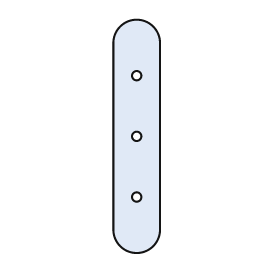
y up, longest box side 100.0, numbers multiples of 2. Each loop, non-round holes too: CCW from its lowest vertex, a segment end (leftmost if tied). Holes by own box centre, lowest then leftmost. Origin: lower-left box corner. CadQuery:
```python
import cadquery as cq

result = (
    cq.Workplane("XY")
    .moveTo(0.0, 10.0)
    .threePointArc((10.0, 0.0), (20.0, 10.0))
    .lineTo(20.0, 90.0)
    .threePointArc((10.0, 100.0), (0.0, 90.0))
    .close()
    .moveTo(10.0, 24.0)
    .circle(2.0)
    .moveTo(10.0, 50.0)
    .circle(2.0)
    .moveTo(10.0, 76.0)
    .circle(2.0)
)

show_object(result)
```